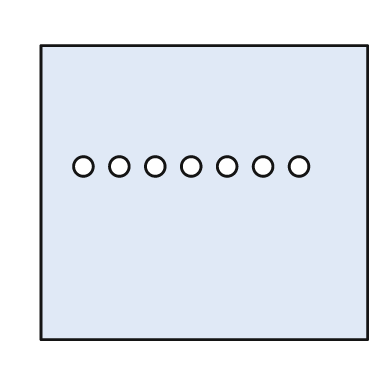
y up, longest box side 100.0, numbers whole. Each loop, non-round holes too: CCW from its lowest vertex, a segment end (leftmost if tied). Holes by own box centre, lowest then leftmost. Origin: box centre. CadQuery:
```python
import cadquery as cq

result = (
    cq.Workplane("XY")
    .moveTo(-50.0, -45.0)
    .lineTo(50.0, -45.0)
    .lineTo(50.0, 45.0)
    .lineTo(-50.0, 45.0)
    .close()
    .moveTo(-37.0, 8.0)
    .circle(3.0)
    .moveTo(-26.0, 8.0)
    .circle(3.0)
    .moveTo(-15.0, 8.0)
    .circle(3.0)
    .moveTo(-4.0, 8.0)
    .circle(3.0)
    .moveTo(7.0, 8.0)
    .circle(3.0)
    .moveTo(18.0, 8.0)
    .circle(3.0)
    .moveTo(29.0, 8.0)
    .circle(3.0)
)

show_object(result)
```